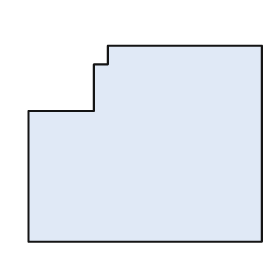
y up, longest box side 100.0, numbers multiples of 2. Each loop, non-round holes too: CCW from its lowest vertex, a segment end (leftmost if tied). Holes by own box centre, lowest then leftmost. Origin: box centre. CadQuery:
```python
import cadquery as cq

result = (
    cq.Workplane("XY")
    .moveTo(-50.0, -42.0)
    .lineTo(50.0, -42.0)
    .lineTo(50.0, 42.0)
    .lineTo(-16.0, 42.0)
    .lineTo(-16.0, 34.0)
    .lineTo(-22.0, 34.0)
    .lineTo(-22.0, 14.0)
    .lineTo(-50.0, 14.0)
    .close()
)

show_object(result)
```